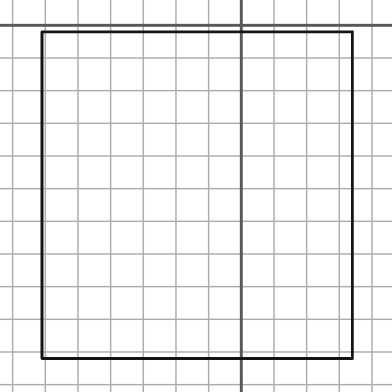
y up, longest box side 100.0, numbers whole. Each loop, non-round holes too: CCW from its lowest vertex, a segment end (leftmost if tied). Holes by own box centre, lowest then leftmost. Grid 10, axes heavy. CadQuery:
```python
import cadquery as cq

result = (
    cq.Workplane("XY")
    .moveTo(-61.0, -102.0)
    .lineTo(34.0, -102.0)
    .lineTo(34.0, -2.0)
    .lineTo(-61.0, -2.0)
    .close()
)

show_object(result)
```